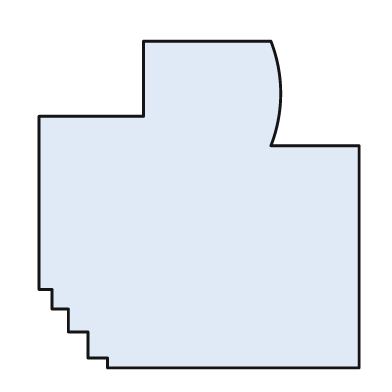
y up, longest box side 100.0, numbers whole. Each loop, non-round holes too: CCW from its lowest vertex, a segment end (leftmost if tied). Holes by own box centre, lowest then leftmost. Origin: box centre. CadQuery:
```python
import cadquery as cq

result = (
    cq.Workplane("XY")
    .moveTo(-28.0, -50.0)
    .lineTo(49.0, -50.0)
    .lineTo(49.0, 18.0)
    .lineTo(22.0, 18.0)
    .threePointArc((25.0, 34.0), (22.0, 50.0))
    .lineTo(-17.0, 50.0)
    .lineTo(-17.0, 27.0)
    .lineTo(-49.0, 27.0)
    .lineTo(-49.0, -26.0)
    .lineTo(-45.0, -26.0)
    .lineTo(-45.0, -32.0)
    .lineTo(-40.0, -32.0)
    .lineTo(-40.0, -39.0)
    .lineTo(-34.0, -39.0)
    .lineTo(-34.0, -47.0)
    .lineTo(-28.0, -47.0)
    .close()
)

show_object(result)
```